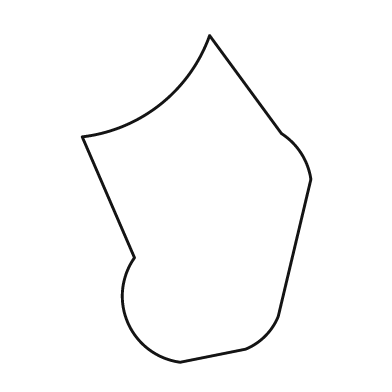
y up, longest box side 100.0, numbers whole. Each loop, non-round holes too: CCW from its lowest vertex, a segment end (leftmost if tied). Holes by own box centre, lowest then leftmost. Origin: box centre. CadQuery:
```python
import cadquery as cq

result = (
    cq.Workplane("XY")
    .moveTo(-5.0, -50.0)
    .lineTo(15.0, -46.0)
    .threePointArc((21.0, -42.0), (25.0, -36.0))
    .lineTo(35.0, 6.0)
    .threePointArc((32.0, 14.0), (26.0, 20.0))
    .lineTo(4.0, 50.0)
    .threePointArc((-11.0, 29.0), (-35.0, 19.0))
    .lineTo(-19.0, -18.0)
    .threePointArc((-21.0, -38.0), (-5.0, -50.0))
    .close()
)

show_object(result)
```